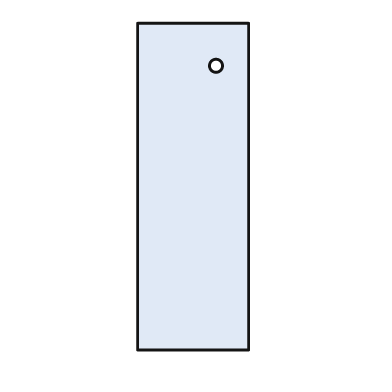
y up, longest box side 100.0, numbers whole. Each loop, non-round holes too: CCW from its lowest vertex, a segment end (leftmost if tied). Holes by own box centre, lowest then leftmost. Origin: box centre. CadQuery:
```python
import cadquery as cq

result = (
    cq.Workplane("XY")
    .moveTo(-17.0, -50.0)
    .lineTo(17.0, -50.0)
    .lineTo(17.0, 50.0)
    .lineTo(-17.0, 50.0)
    .close()
    .moveTo(7.0, 37.0)
    .circle(2.0)
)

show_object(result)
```